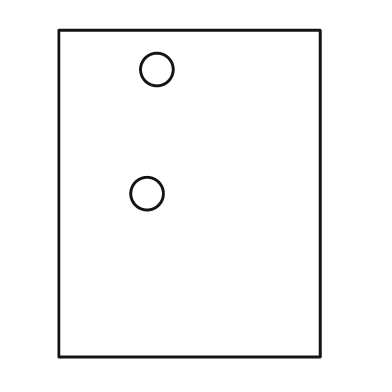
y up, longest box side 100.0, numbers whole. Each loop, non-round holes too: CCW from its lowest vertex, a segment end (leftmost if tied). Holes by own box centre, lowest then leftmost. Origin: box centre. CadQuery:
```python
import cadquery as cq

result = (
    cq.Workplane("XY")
    .moveTo(-40.0, -50.0)
    .lineTo(40.0, -50.0)
    .lineTo(40.0, 50.0)
    .lineTo(-40.0, 50.0)
    .close()
    .moveTo(-13.0, 0.0)
    .circle(5.0)
    .moveTo(-10.0, 38.0)
    .circle(5.0)
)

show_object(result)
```